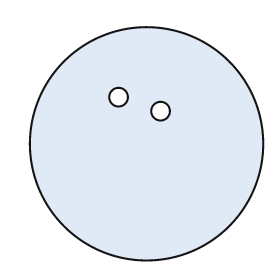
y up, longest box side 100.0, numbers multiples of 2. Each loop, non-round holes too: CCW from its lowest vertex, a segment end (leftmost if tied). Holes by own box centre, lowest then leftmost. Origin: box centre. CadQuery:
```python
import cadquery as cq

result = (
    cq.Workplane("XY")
    .moveTo(0.0, 0.0)
    .circle(50.0)
    .moveTo(6.0, 14.0)
    .circle(4.0)
    .moveTo(-12.0, 20.0)
    .circle(4.0)
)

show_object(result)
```